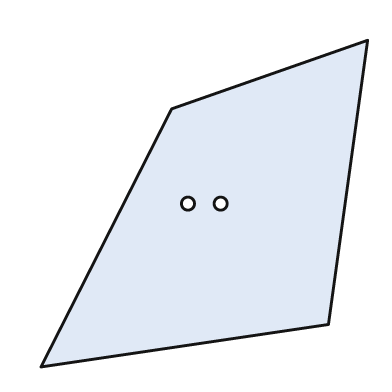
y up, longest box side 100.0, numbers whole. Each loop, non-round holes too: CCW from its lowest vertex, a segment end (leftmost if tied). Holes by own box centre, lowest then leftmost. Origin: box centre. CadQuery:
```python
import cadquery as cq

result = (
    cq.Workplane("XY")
    .moveTo(-50.0, -50.0)
    .lineTo(38.0, -37.0)
    .lineTo(50.0, 50.0)
    .lineTo(-10.0, 29.0)
    .close()
    .moveTo(-5.0, 0.0)
    .circle(2.0)
    .moveTo(5.0, 0.0)
    .circle(2.0)
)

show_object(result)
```